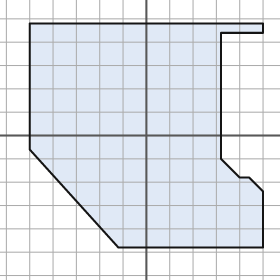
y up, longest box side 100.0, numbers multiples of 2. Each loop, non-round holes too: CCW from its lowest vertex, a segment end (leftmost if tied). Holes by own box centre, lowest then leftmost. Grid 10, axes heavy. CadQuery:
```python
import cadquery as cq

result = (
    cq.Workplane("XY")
    .moveTo(-12.0, -48.0)
    .lineTo(50.0, -48.0)
    .lineTo(50.0, -24.0)
    .lineTo(44.0, -18.0)
    .lineTo(40.0, -18.0)
    .lineTo(32.0, -10.0)
    .lineTo(32.0, 44.0)
    .lineTo(50.0, 44.0)
    .lineTo(50.0, 48.0)
    .lineTo(-50.0, 48.0)
    .lineTo(-50.0, -6.0)
    .close()
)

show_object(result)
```